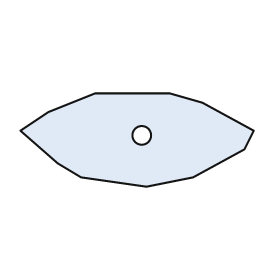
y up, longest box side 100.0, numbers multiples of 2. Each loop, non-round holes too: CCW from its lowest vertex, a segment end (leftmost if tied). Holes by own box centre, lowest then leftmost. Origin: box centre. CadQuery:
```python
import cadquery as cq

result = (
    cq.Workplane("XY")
    .moveTo(4.0, -20.0)
    .lineTo(24.0, -16.0)
    .lineTo(46.0, -4.0)
    .lineTo(50.0, 4.0)
    .lineTo(28.0, 16.0)
    .lineTo(14.0, 20.0)
    .lineTo(-18.0, 20.0)
    .lineTo(-38.0, 12.0)
    .lineTo(-50.0, 4.0)
    .lineTo(-34.0, -10.0)
    .lineTo(-24.0, -16.0)
    .close()
    .moveTo(2.0, 2.0)
    .circle(4.0)
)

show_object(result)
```